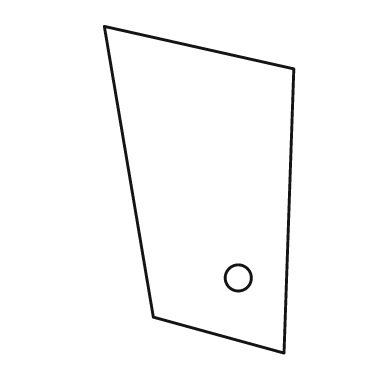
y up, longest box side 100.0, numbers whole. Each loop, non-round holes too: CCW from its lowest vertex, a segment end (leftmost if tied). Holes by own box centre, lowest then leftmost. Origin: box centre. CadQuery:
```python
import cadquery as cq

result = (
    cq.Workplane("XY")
    .moveTo(26.0, -50.0)
    .lineTo(29.0, 37.0)
    .lineTo(-29.0, 50.0)
    .lineTo(-14.0, -39.0)
    .close()
    .moveTo(12.0, -27.0)
    .circle(4.0)
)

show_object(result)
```